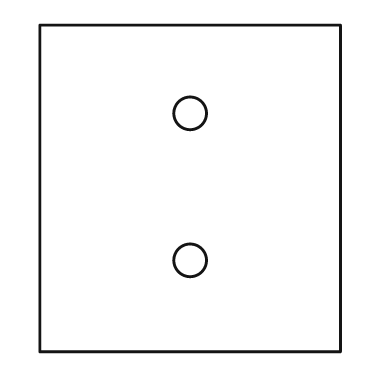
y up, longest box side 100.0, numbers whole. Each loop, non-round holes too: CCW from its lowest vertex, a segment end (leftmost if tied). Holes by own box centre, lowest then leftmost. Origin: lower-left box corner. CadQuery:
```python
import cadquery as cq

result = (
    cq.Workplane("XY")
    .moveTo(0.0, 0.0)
    .lineTo(92.0, 0.0)
    .lineTo(92.0, 100.0)
    .lineTo(0.0, 100.0)
    .close()
    .moveTo(46.0, 28.0)
    .circle(5.0)
    .moveTo(46.0, 73.0)
    .circle(5.0)
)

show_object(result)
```